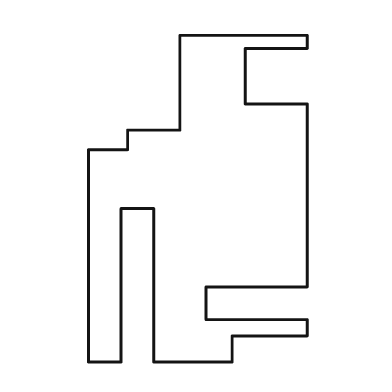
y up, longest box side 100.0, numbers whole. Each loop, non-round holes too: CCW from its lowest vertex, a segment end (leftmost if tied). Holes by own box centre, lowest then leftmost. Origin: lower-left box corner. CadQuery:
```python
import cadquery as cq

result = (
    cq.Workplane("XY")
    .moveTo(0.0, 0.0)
    .lineTo(10.0, 0.0)
    .lineTo(10.0, 47.0)
    .lineTo(20.0, 47.0)
    .lineTo(20.0, 0.0)
    .lineTo(44.0, 0.0)
    .lineTo(44.0, 8.0)
    .lineTo(67.0, 8.0)
    .lineTo(67.0, 13.0)
    .lineTo(36.0, 13.0)
    .lineTo(36.0, 23.0)
    .lineTo(67.0, 23.0)
    .lineTo(67.0, 79.0)
    .lineTo(48.0, 79.0)
    .lineTo(48.0, 96.0)
    .lineTo(67.0, 96.0)
    .lineTo(67.0, 100.0)
    .lineTo(28.0, 100.0)
    .lineTo(28.0, 71.0)
    .lineTo(12.0, 71.0)
    .lineTo(12.0, 65.0)
    .lineTo(0.0, 65.0)
    .close()
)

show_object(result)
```